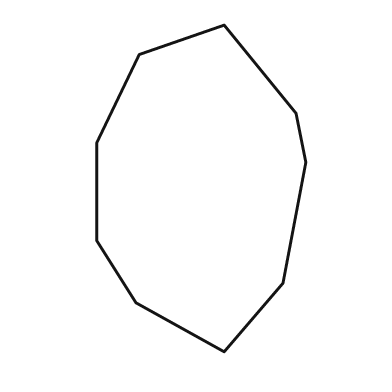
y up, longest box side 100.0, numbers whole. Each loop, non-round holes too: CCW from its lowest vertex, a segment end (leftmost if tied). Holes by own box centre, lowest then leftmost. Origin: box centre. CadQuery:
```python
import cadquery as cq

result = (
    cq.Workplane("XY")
    .moveTo(7.0, -50.0)
    .lineTo(25.0, -29.0)
    .lineTo(32.0, 8.0)
    .lineTo(29.0, 23.0)
    .lineTo(7.0, 50.0)
    .lineTo(-19.0, 41.0)
    .lineTo(-32.0, 14.0)
    .lineTo(-32.0, -16.0)
    .lineTo(-20.0, -35.0)
    .close()
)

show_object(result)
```